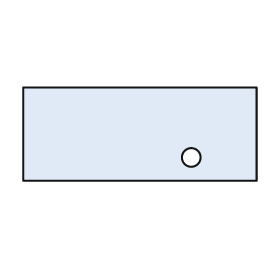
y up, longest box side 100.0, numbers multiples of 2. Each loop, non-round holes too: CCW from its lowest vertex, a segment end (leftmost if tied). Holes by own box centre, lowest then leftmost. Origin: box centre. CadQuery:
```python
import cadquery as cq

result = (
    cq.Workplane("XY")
    .moveTo(-50.0, -20.0)
    .lineTo(50.0, -20.0)
    .lineTo(50.0, 20.0)
    .lineTo(-50.0, 20.0)
    .close()
    .moveTo(22.0, -10.0)
    .circle(4.0)
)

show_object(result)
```